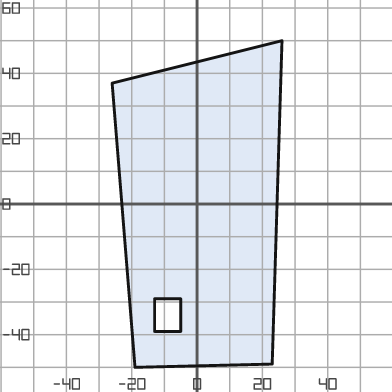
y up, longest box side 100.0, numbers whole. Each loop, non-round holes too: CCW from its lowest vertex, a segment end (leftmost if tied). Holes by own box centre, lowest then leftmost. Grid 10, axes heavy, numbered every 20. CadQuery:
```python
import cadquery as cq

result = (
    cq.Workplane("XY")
    .moveTo(-19.0, -50.0)
    .lineTo(23.0, -49.0)
    .lineTo(26.0, 50.0)
    .lineTo(-26.0, 37.0)
    .close()
    .moveTo(-13.0, -39.0)
    .lineTo(-5.0, -39.0)
    .lineTo(-5.0, -29.0)
    .lineTo(-13.0, -29.0)
    .close()
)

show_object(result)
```